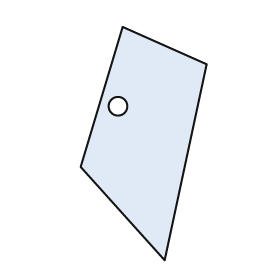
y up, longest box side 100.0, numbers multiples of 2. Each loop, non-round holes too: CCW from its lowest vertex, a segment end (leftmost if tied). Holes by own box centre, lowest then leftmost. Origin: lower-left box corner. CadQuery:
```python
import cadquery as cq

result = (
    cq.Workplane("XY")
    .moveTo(36.0, 0.0)
    .lineTo(54.0, 84.0)
    .lineTo(18.0, 100.0)
    .lineTo(0.0, 40.0)
    .close()
    .moveTo(16.0, 66.0)
    .circle(4.0)
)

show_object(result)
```